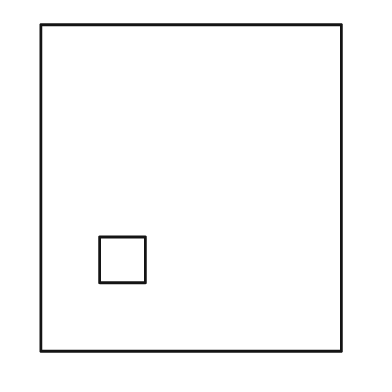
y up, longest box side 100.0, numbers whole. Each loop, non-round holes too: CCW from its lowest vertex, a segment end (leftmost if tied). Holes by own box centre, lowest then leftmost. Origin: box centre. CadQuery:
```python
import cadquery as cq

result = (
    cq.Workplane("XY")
    .moveTo(-46.0, -50.0)
    .lineTo(46.0, -50.0)
    .lineTo(46.0, 50.0)
    .lineTo(-46.0, 50.0)
    .close()
    .moveTo(-28.0, -29.0)
    .lineTo(-14.0, -29.0)
    .lineTo(-14.0, -15.0)
    .lineTo(-28.0, -15.0)
    .close()
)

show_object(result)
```